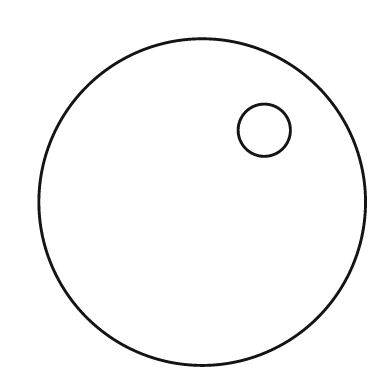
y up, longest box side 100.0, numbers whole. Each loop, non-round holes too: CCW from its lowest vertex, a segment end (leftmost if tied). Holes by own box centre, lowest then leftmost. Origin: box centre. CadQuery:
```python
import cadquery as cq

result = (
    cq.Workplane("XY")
    .moveTo(0.0, 0.0)
    .circle(50.0)
    .moveTo(19.0, 22.0)
    .circle(8.0)
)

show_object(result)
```